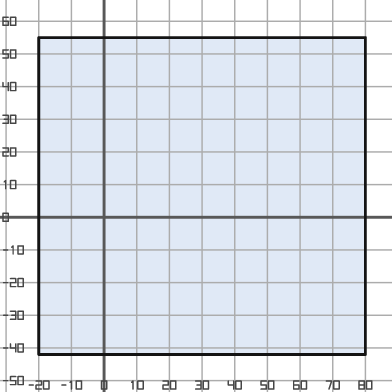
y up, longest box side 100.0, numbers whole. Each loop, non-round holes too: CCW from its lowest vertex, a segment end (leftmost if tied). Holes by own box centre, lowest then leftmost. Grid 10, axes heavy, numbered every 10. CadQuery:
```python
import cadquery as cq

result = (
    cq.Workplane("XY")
    .moveTo(-20.0, -42.0)
    .lineTo(80.0, -42.0)
    .lineTo(80.0, 55.0)
    .lineTo(-20.0, 55.0)
    .close()
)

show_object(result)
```